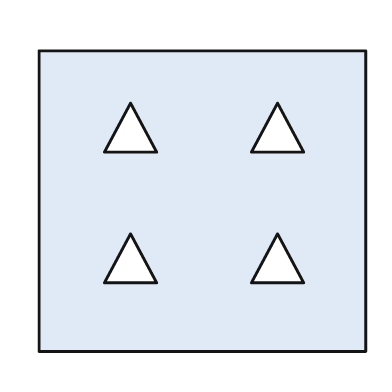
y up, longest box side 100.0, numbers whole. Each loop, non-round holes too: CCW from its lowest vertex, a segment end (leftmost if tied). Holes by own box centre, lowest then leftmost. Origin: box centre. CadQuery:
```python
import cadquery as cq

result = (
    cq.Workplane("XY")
    .moveTo(-50.0, -46.0)
    .lineTo(50.0, -46.0)
    .lineTo(50.0, 46.0)
    .lineTo(-50.0, 46.0)
    .close()
    .moveTo(-30.0, -25.0)
    .lineTo(-14.0, -25.0)
    .lineTo(-22.0, -10.0)
    .close()
    .moveTo(15.0, -25.0)
    .lineTo(31.0, -25.0)
    .lineTo(23.0, -10.0)
    .close()
    .moveTo(-30.0, 15.0)
    .lineTo(-14.0, 15.0)
    .lineTo(-22.0, 30.0)
    .close()
    .moveTo(15.0, 15.0)
    .lineTo(31.0, 15.0)
    .lineTo(23.0, 30.0)
    .close()
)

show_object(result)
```